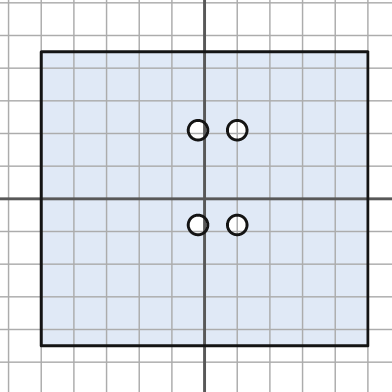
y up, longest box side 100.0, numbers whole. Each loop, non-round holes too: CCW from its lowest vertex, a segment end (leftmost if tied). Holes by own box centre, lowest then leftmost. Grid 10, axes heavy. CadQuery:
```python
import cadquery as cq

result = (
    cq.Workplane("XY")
    .moveTo(-50.0, -45.0)
    .lineTo(50.0, -45.0)
    .lineTo(50.0, 45.0)
    .lineTo(-50.0, 45.0)
    .close()
    .moveTo(-2.0, -8.0)
    .circle(3.0)
    .moveTo(10.0, -8.0)
    .circle(3.0)
    .moveTo(-2.0, 21.0)
    .circle(3.0)
    .moveTo(10.0, 21.0)
    .circle(3.0)
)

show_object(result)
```